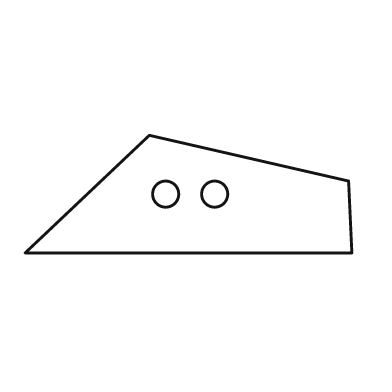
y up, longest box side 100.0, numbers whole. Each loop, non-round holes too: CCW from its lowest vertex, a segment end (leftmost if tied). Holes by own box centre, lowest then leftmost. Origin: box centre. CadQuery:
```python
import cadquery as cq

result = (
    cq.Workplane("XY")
    .moveTo(-50.0, -18.0)
    .lineTo(50.0, -18.0)
    .lineTo(49.0, 4.0)
    .lineTo(-12.0, 18.0)
    .close()
    .moveTo(-7.0, 0.0)
    .circle(4.0)
    .moveTo(8.0, 0.0)
    .circle(4.0)
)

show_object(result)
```